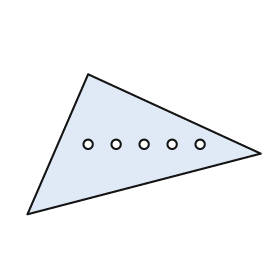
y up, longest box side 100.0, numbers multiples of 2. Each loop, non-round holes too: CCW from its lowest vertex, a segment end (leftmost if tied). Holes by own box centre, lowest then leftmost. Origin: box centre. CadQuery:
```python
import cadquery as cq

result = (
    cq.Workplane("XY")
    .moveTo(-50.0, -30.0)
    .lineTo(50.0, -4.0)
    .lineTo(-24.0, 30.0)
    .close()
    .moveTo(-24.0, 0.0)
    .circle(2.0)
    .moveTo(-12.0, 0.0)
    .circle(2.0)
    .moveTo(0.0, 0.0)
    .circle(2.0)
    .moveTo(12.0, 0.0)
    .circle(2.0)
    .moveTo(24.0, 0.0)
    .circle(2.0)
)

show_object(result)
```